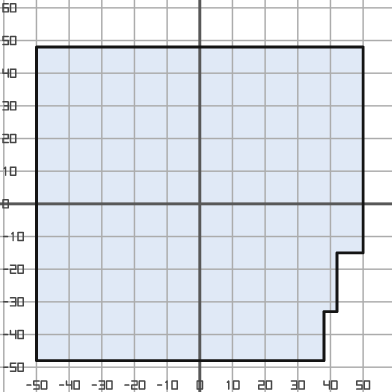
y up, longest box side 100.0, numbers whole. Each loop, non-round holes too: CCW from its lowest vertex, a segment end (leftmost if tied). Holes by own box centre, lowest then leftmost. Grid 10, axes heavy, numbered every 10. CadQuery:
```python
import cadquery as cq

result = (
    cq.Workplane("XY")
    .moveTo(-50.0, -48.0)
    .lineTo(38.0, -48.0)
    .lineTo(38.0, -33.0)
    .lineTo(42.0, -33.0)
    .lineTo(42.0, -15.0)
    .lineTo(50.0, -15.0)
    .lineTo(50.0, 48.0)
    .lineTo(-50.0, 48.0)
    .close()
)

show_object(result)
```